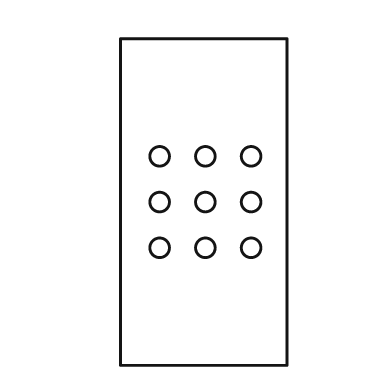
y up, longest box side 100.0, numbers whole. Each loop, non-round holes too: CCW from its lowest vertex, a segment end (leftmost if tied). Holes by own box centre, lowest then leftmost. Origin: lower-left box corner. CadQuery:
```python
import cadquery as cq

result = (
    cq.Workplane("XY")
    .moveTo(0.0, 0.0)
    .lineTo(51.0, 0.0)
    .lineTo(51.0, 100.0)
    .lineTo(0.0, 100.0)
    .close()
    .moveTo(12.0, 36.0)
    .circle(3.0)
    .moveTo(26.0, 36.0)
    .circle(3.0)
    .moveTo(40.0, 36.0)
    .circle(3.0)
    .moveTo(12.0, 50.0)
    .circle(3.0)
    .moveTo(26.0, 50.0)
    .circle(3.0)
    .moveTo(40.0, 50.0)
    .circle(3.0)
    .moveTo(12.0, 64.0)
    .circle(3.0)
    .moveTo(26.0, 64.0)
    .circle(3.0)
    .moveTo(40.0, 64.0)
    .circle(3.0)
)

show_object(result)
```